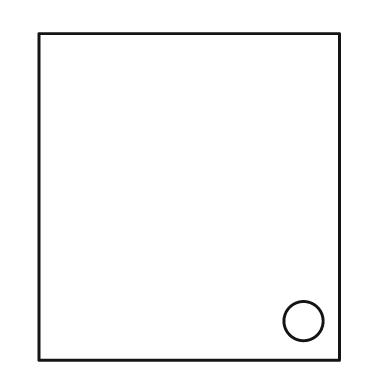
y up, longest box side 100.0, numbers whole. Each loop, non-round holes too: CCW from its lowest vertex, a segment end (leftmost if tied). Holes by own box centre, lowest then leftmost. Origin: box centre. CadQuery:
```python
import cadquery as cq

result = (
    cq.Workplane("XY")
    .moveTo(-46.0, -50.0)
    .lineTo(46.0, -50.0)
    .lineTo(46.0, 50.0)
    .lineTo(-46.0, 50.0)
    .close()
    .moveTo(35.0, -38.0)
    .circle(6.0)
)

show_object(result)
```